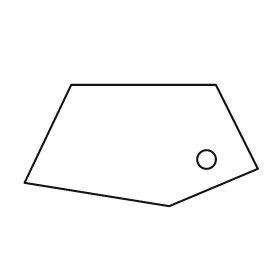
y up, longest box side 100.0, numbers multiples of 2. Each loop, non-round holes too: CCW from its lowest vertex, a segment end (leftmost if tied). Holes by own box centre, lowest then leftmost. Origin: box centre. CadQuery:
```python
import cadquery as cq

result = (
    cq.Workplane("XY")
    .moveTo(12.0, -26.0)
    .lineTo(50.0, -10.0)
    .lineTo(32.0, 26.0)
    .lineTo(-30.0, 26.0)
    .lineTo(-50.0, -16.0)
    .close()
    .moveTo(28.0, -6.0)
    .circle(4.0)
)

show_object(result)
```